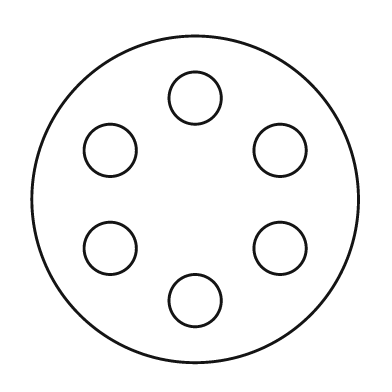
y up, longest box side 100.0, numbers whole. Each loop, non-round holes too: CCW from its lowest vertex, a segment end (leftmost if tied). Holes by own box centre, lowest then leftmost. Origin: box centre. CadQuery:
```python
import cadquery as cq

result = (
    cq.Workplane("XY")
    .moveTo(0.0, 0.0)
    .circle(50.0)
    .moveTo(0.0, -31.0)
    .circle(8.0)
    .moveTo(-26.0, -15.0)
    .circle(8.0)
    .moveTo(26.0, -15.0)
    .circle(8.0)
    .moveTo(-26.0, 15.0)
    .circle(8.0)
    .moveTo(26.0, 15.0)
    .circle(8.0)
    .moveTo(0.0, 31.0)
    .circle(8.0)
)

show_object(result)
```